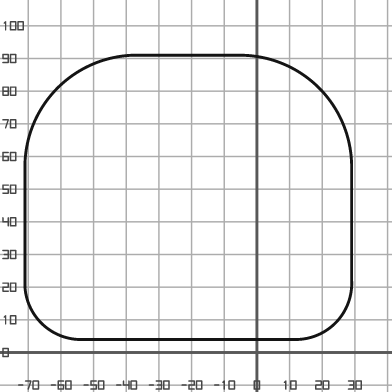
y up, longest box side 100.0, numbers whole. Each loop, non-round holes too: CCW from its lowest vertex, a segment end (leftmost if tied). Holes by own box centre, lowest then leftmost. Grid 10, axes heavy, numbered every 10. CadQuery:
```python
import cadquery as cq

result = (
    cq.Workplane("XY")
    .moveTo(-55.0, 4.0)
    .lineTo(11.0, 4.0)
    .threePointArc((24.0, 9.0), (29.0, 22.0))
    .lineTo(29.0, 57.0)
    .threePointArc((19.0, 81.0), (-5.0, 91.0))
    .lineTo(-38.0, 91.0)
    .threePointArc((-61.0, 81.0), (-71.0, 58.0))
    .lineTo(-71.0, 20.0)
    .threePointArc((-66.0, 9.0), (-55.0, 4.0))
    .close()
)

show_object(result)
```